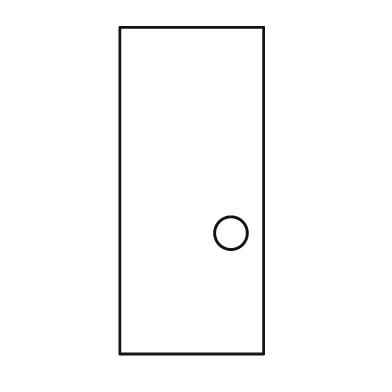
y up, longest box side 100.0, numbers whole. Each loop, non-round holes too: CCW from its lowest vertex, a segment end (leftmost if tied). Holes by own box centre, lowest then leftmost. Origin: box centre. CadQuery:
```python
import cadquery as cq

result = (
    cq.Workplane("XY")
    .moveTo(-22.0, -50.0)
    .lineTo(22.0, -50.0)
    .lineTo(22.0, 50.0)
    .lineTo(-22.0, 50.0)
    .close()
    .moveTo(12.0, -13.0)
    .circle(5.0)
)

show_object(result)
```